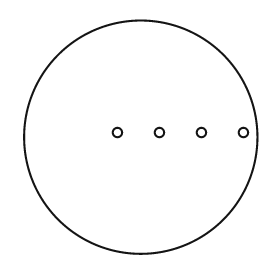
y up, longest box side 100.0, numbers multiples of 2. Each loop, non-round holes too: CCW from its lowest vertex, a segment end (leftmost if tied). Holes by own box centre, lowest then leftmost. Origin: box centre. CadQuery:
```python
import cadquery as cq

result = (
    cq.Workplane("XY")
    .moveTo(0.0, 0.0)
    .circle(50.0)
    .moveTo(-10.0, 2.0)
    .circle(2.0)
    .moveTo(8.0, 2.0)
    .circle(2.0)
    .moveTo(26.0, 2.0)
    .circle(2.0)
    .moveTo(44.0, 2.0)
    .circle(2.0)
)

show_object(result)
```